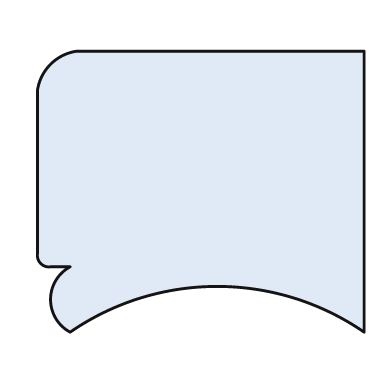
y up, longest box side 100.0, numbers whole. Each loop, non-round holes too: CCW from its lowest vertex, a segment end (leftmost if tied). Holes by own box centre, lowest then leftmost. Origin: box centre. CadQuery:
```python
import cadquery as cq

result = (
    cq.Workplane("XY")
    .moveTo(-40.0, -43.0)
    .threePointArc((5.0, -29.0), (50.0, -43.0))
    .lineTo(50.0, 43.0)
    .lineTo(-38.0, 43.0)
    .threePointArc((-46.0, 39.0), (-50.0, 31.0))
    .lineTo(-50.0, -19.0)
    .threePointArc((-49.0, -22.0), (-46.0, -23.0))
    .lineTo(-40.0, -23.0)
    .threePointArc((-46.0, -33.0), (-40.0, -43.0))
    .close()
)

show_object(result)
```